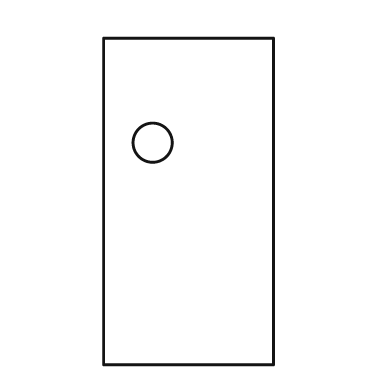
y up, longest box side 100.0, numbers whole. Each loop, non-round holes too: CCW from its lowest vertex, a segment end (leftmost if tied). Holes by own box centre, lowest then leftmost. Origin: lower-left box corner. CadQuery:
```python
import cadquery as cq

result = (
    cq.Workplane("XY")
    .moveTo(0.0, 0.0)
    .lineTo(52.0, 0.0)
    .lineTo(52.0, 100.0)
    .lineTo(0.0, 100.0)
    .close()
    .moveTo(15.0, 68.0)
    .circle(6.0)
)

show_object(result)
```